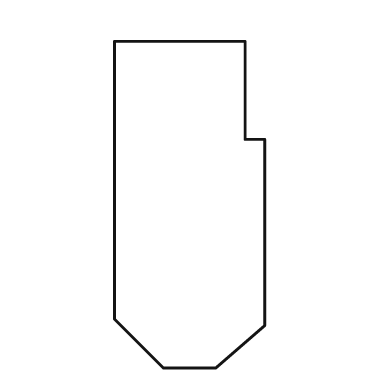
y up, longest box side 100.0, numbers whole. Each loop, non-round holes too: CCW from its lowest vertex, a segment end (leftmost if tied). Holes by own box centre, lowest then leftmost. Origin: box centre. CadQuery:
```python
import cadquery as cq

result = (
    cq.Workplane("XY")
    .moveTo(-8.0, -50.0)
    .lineTo(8.0, -50.0)
    .lineTo(23.0, -37.0)
    .lineTo(23.0, 20.0)
    .lineTo(17.0, 20.0)
    .lineTo(17.0, 50.0)
    .lineTo(-23.0, 50.0)
    .lineTo(-23.0, -35.0)
    .close()
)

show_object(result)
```